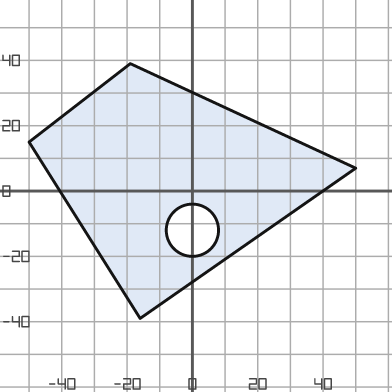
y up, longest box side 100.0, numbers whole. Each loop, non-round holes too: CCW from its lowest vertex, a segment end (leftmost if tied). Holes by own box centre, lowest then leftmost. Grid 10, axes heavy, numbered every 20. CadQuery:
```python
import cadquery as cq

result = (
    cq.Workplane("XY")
    .moveTo(-16.0, -39.0)
    .lineTo(50.0, 7.0)
    .lineTo(-19.0, 39.0)
    .lineTo(-50.0, 15.0)
    .close()
    .moveTo(0.0, -12.0)
    .circle(8.0)
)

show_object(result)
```